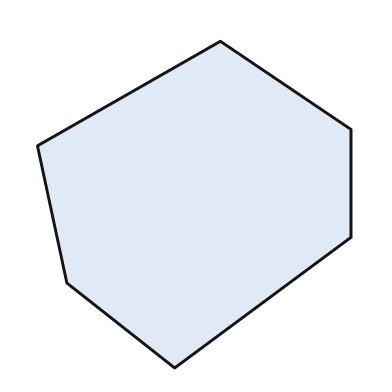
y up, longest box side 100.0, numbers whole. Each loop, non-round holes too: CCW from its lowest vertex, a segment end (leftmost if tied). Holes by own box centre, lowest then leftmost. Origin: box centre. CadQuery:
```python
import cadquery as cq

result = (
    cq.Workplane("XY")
    .moveTo(-6.0, -50.0)
    .lineTo(48.0, -10.0)
    .lineTo(48.0, 23.0)
    .lineTo(8.0, 50.0)
    .lineTo(-48.0, 18.0)
    .lineTo(-39.0, -24.0)
    .close()
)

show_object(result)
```